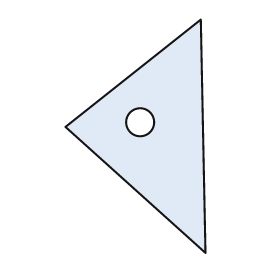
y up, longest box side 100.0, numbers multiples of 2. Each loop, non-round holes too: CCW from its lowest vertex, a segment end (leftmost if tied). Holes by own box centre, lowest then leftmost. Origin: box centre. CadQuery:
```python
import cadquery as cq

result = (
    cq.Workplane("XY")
    .moveTo(30.0, -50.0)
    .lineTo(28.0, 50.0)
    .lineTo(-30.0, 4.0)
    .close()
    .moveTo(2.0, 6.0)
    .circle(6.0)
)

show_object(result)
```